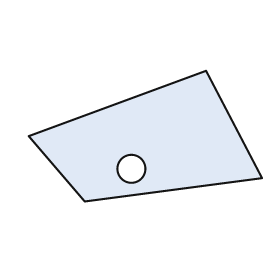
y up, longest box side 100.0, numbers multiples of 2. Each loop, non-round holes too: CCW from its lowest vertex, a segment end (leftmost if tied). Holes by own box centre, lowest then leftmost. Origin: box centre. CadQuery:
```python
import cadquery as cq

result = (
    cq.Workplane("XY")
    .moveTo(-26.0, -28.0)
    .lineTo(50.0, -18.0)
    .lineTo(26.0, 28.0)
    .lineTo(-50.0, 0.0)
    .close()
    .moveTo(-6.0, -14.0)
    .circle(6.0)
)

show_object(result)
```